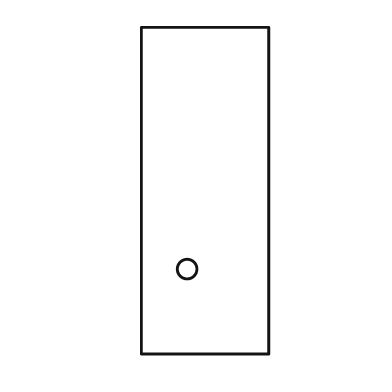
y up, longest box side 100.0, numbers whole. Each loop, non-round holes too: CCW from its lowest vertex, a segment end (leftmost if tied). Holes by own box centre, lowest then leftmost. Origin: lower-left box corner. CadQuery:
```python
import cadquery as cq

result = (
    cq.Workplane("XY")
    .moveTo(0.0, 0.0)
    .lineTo(39.0, 0.0)
    .lineTo(39.0, 100.0)
    .lineTo(0.0, 100.0)
    .close()
    .moveTo(14.0, 26.0)
    .circle(3.0)
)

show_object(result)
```